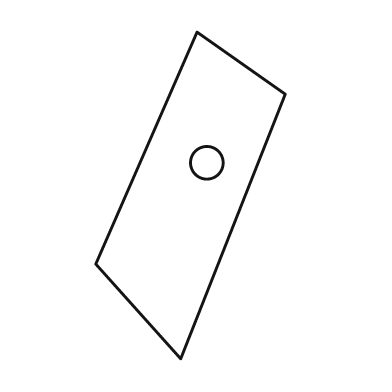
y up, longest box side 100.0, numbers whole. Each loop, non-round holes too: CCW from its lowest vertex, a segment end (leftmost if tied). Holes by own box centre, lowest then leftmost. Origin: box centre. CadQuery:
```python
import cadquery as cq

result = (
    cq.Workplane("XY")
    .moveTo(-3.0, -50.0)
    .lineTo(29.0, 31.0)
    .lineTo(2.0, 50.0)
    .lineTo(-29.0, -21.0)
    .close()
    .moveTo(5.0, 10.0)
    .circle(5.0)
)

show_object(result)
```